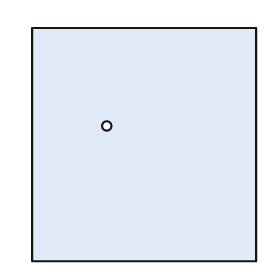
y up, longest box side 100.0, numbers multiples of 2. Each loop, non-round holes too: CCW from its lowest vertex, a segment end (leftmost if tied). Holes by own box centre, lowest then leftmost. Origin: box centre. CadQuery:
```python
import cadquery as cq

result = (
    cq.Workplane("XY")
    .moveTo(-48.0, -50.0)
    .lineTo(48.0, -50.0)
    .lineTo(48.0, 50.0)
    .lineTo(-48.0, 50.0)
    .close()
    .moveTo(-16.0, 8.0)
    .circle(2.0)
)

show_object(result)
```